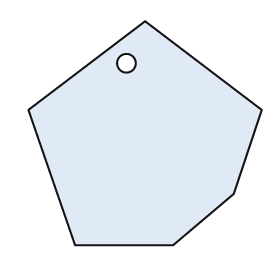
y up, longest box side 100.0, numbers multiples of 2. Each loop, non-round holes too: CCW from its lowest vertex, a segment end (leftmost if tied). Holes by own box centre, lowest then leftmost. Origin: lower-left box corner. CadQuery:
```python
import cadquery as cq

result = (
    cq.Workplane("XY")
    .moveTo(20.0, 0.0)
    .lineTo(62.0, 0.0)
    .lineTo(88.0, 22.0)
    .lineTo(100.0, 58.0)
    .lineTo(50.0, 96.0)
    .lineTo(0.0, 58.0)
    .close()
    .moveTo(42.0, 78.0)
    .circle(4.0)
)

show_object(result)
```